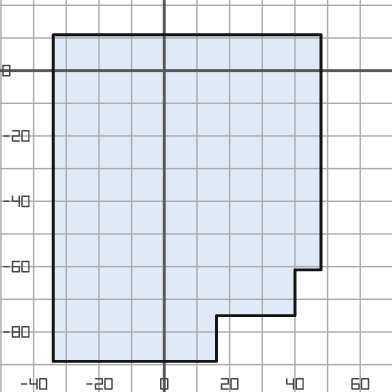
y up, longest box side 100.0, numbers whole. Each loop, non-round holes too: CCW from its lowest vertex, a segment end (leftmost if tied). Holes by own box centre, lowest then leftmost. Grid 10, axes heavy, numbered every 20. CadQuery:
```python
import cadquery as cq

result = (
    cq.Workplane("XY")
    .moveTo(-34.0, -89.0)
    .lineTo(16.0, -89.0)
    .lineTo(16.0, -75.0)
    .lineTo(40.0, -75.0)
    .lineTo(40.0, -61.0)
    .lineTo(48.0, -61.0)
    .lineTo(48.0, 11.0)
    .lineTo(-34.0, 11.0)
    .close()
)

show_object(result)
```